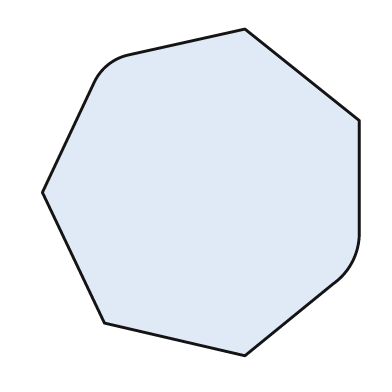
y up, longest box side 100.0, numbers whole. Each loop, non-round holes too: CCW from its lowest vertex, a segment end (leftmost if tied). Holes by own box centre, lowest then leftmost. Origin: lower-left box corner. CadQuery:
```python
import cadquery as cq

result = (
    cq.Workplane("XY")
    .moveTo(62.0, 0.0)
    .lineTo(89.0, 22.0)
    .threePointArc((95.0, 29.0), (97.0, 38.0))
    .lineTo(97.0, 72.0)
    .lineTo(62.0, 100.0)
    .lineTo(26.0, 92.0)
    .threePointArc((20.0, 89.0), (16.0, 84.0))
    .lineTo(0.0, 50.0)
    .lineTo(19.0, 10.0)
    .close()
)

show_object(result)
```